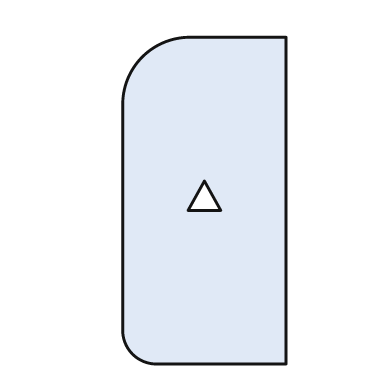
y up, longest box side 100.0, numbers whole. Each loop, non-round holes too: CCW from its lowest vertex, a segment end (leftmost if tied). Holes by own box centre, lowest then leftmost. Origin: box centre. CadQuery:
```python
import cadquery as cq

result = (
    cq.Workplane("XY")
    .moveTo(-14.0, -50.0)
    .lineTo(25.0, -50.0)
    .lineTo(25.0, 50.0)
    .lineTo(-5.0, 50.0)
    .threePointArc((-19.0, 44.0), (-25.0, 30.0))
    .lineTo(-25.0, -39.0)
    .threePointArc((-22.0, -47.0), (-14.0, -50.0))
    .close()
    .moveTo(-5.0, -3.0)
    .lineTo(5.0, -3.0)
    .lineTo(0.0, 6.0)
    .close()
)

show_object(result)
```